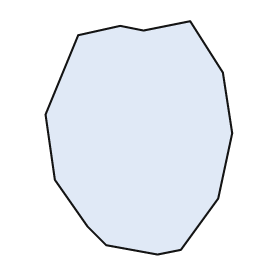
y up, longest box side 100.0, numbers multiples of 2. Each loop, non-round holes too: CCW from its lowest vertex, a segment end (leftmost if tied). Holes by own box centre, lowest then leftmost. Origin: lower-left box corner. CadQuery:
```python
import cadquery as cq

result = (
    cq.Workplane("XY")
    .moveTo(48.0, 0.0)
    .lineTo(58.0, 2.0)
    .lineTo(74.0, 24.0)
    .lineTo(80.0, 52.0)
    .lineTo(76.0, 78.0)
    .lineTo(62.0, 100.0)
    .lineTo(42.0, 96.0)
    .lineTo(32.0, 98.0)
    .lineTo(14.0, 94.0)
    .lineTo(0.0, 60.0)
    .lineTo(4.0, 32.0)
    .lineTo(18.0, 12.0)
    .lineTo(26.0, 4.0)
    .close()
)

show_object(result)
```